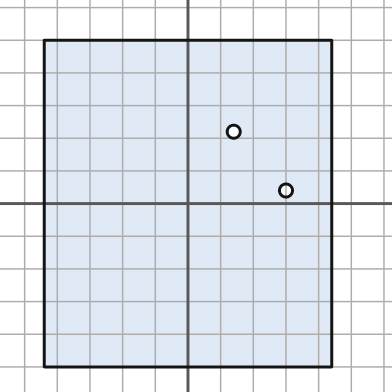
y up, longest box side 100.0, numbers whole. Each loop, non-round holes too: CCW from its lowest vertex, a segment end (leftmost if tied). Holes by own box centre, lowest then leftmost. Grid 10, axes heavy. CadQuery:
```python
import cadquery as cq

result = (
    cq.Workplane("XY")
    .moveTo(-44.0, -50.0)
    .lineTo(44.0, -50.0)
    .lineTo(44.0, 50.0)
    .lineTo(-44.0, 50.0)
    .close()
    .moveTo(30.0, 4.0)
    .circle(2.0)
    .moveTo(14.0, 22.0)
    .circle(2.0)
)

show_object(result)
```